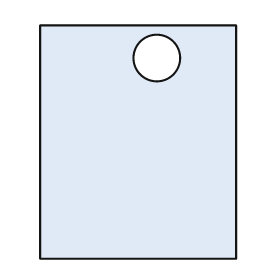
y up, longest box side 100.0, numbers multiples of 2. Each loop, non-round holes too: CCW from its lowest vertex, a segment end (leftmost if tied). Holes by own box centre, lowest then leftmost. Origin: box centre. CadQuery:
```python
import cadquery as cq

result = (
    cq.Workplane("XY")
    .moveTo(-42.0, -50.0)
    .lineTo(42.0, -50.0)
    .lineTo(42.0, 50.0)
    .lineTo(-42.0, 50.0)
    .close()
    .moveTo(8.0, 36.0)
    .circle(10.0)
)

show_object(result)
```